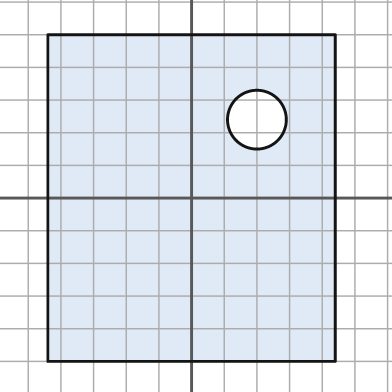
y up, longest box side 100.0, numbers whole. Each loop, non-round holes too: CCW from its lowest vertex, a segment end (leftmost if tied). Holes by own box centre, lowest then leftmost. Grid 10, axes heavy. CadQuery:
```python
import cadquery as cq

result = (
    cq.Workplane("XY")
    .moveTo(-44.0, -50.0)
    .lineTo(44.0, -50.0)
    .lineTo(44.0, 50.0)
    .lineTo(-44.0, 50.0)
    .close()
    .moveTo(20.0, 24.0)
    .circle(9.0)
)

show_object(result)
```